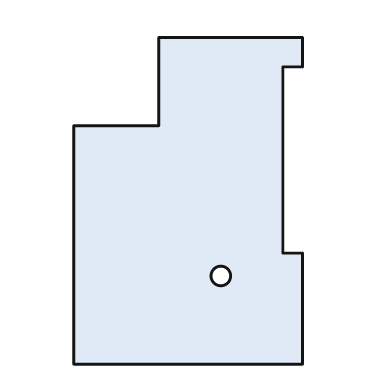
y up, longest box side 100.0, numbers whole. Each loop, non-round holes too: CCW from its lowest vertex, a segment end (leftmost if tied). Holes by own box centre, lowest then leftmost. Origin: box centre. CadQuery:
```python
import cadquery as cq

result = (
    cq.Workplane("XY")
    .moveTo(-35.0, -50.0)
    .lineTo(35.0, -50.0)
    .lineTo(35.0, -16.0)
    .lineTo(29.0, -16.0)
    .lineTo(29.0, 41.0)
    .lineTo(35.0, 41.0)
    .lineTo(35.0, 50.0)
    .lineTo(-9.0, 50.0)
    .lineTo(-9.0, 23.0)
    .lineTo(-35.0, 23.0)
    .close()
    .moveTo(10.0, -23.0)
    .circle(3.0)
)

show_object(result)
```